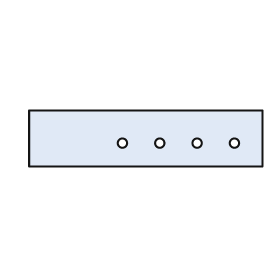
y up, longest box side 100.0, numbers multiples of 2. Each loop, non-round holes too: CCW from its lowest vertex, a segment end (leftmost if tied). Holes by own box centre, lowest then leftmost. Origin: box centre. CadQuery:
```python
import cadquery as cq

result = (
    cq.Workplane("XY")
    .moveTo(-50.0, -12.0)
    .lineTo(50.0, -12.0)
    .lineTo(50.0, 12.0)
    .lineTo(-50.0, 12.0)
    .close()
    .moveTo(-10.0, -2.0)
    .circle(2.0)
    .moveTo(6.0, -2.0)
    .circle(2.0)
    .moveTo(22.0, -2.0)
    .circle(2.0)
    .moveTo(38.0, -2.0)
    .circle(2.0)
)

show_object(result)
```